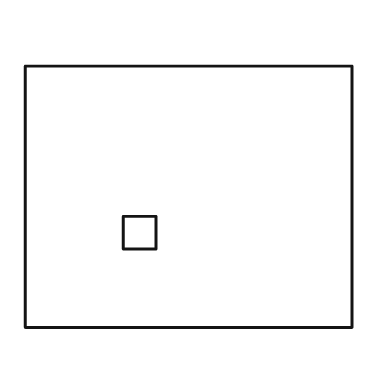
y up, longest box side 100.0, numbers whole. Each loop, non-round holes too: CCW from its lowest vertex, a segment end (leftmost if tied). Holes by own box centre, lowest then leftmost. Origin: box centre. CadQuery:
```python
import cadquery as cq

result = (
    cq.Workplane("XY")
    .moveTo(-50.0, -40.0)
    .lineTo(50.0, -40.0)
    .lineTo(50.0, 40.0)
    .lineTo(-50.0, 40.0)
    .close()
    .moveTo(-20.0, -16.0)
    .lineTo(-10.0, -16.0)
    .lineTo(-10.0, -6.0)
    .lineTo(-20.0, -6.0)
    .close()
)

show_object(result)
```